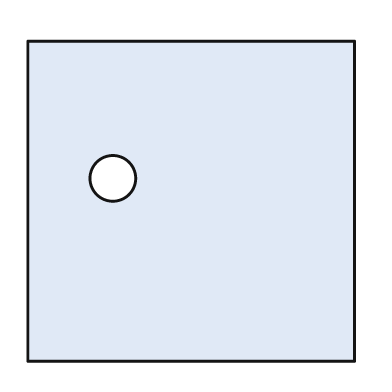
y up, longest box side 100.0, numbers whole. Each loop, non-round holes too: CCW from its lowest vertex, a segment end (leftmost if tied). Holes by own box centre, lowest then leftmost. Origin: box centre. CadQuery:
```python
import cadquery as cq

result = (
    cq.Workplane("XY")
    .moveTo(-50.0, -49.0)
    .lineTo(50.0, -49.0)
    .lineTo(50.0, 49.0)
    .lineTo(-50.0, 49.0)
    .close()
    .moveTo(-24.0, 7.0)
    .circle(7.0)
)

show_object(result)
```